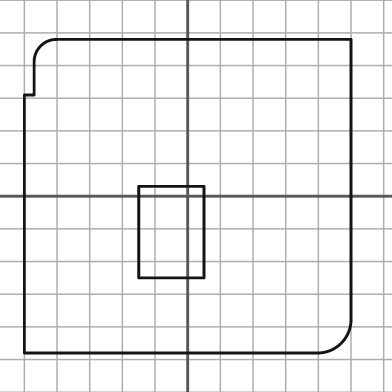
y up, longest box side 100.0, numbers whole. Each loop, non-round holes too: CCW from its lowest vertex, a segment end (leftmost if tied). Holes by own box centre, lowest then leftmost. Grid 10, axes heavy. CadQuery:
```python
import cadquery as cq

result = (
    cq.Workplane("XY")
    .moveTo(-50.0, -48.0)
    .lineTo(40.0, -48.0)
    .threePointArc((47.0, -45.0), (50.0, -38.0))
    .lineTo(50.0, 48.0)
    .lineTo(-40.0, 48.0)
    .threePointArc((-45.0, 46.0), (-47.0, 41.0))
    .lineTo(-47.0, 31.0)
    .lineTo(-50.0, 31.0)
    .close()
    .moveTo(-15.0, -25.0)
    .lineTo(5.0, -25.0)
    .lineTo(5.0, 3.0)
    .lineTo(-15.0, 3.0)
    .close()
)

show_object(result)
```